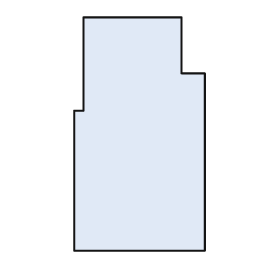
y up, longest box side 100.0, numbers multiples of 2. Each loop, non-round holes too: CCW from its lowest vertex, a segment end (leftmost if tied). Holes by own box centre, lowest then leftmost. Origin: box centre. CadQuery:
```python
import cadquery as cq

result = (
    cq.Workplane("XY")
    .moveTo(-28.0, -50.0)
    .lineTo(28.0, -50.0)
    .lineTo(28.0, 26.0)
    .lineTo(18.0, 26.0)
    .lineTo(18.0, 50.0)
    .lineTo(-24.0, 50.0)
    .lineTo(-24.0, 10.0)
    .lineTo(-28.0, 10.0)
    .close()
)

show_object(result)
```